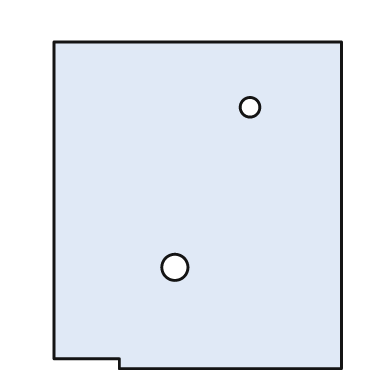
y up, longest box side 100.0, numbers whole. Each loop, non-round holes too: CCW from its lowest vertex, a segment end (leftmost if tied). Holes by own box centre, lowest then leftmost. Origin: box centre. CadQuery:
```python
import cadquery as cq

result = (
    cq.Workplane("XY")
    .moveTo(-24.0, -50.0)
    .lineTo(44.0, -50.0)
    .lineTo(44.0, 50.0)
    .lineTo(-44.0, 50.0)
    .lineTo(-44.0, -47.0)
    .lineTo(-24.0, -47.0)
    .close()
    .moveTo(-7.0, -19.0)
    .circle(4.0)
    .moveTo(16.0, 30.0)
    .circle(3.0)
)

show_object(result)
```